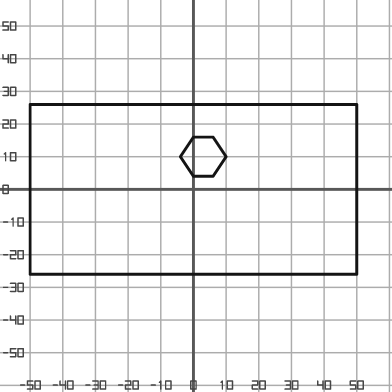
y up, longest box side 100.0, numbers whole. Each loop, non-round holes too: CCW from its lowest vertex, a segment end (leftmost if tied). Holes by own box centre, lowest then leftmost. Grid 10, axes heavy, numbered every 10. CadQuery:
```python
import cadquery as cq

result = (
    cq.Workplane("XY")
    .moveTo(-50.0, -26.0)
    .lineTo(50.0, -26.0)
    .lineTo(50.0, 26.0)
    .lineTo(-50.0, 26.0)
    .close()
    .moveTo(0.0, 4.0)
    .lineTo(6.0, 4.0)
    .lineTo(10.0, 10.0)
    .lineTo(6.0, 16.0)
    .lineTo(0.0, 16.0)
    .lineTo(-4.0, 10.0)
    .close()
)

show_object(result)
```